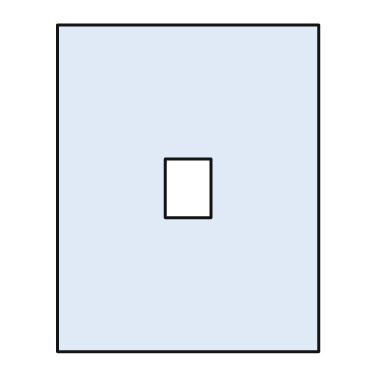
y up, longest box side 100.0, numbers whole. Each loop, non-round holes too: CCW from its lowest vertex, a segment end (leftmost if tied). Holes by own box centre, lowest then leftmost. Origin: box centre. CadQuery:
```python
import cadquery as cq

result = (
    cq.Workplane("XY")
    .moveTo(-40.0, -50.0)
    .lineTo(40.0, -50.0)
    .lineTo(40.0, 50.0)
    .lineTo(-40.0, 50.0)
    .close()
    .moveTo(-7.0, -9.0)
    .lineTo(7.0, -9.0)
    .lineTo(7.0, 9.0)
    .lineTo(-7.0, 9.0)
    .close()
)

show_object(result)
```